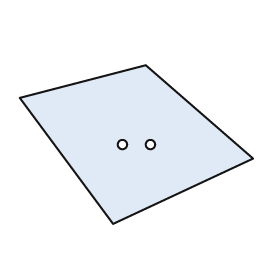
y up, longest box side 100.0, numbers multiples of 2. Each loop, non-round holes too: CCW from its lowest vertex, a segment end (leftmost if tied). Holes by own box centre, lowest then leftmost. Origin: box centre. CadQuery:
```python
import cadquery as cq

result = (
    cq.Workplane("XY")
    .moveTo(-10.0, -34.0)
    .lineTo(50.0, -6.0)
    .lineTo(4.0, 34.0)
    .lineTo(-50.0, 20.0)
    .close()
    .moveTo(-6.0, 0.0)
    .circle(2.0)
    .moveTo(6.0, 0.0)
    .circle(2.0)
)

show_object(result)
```